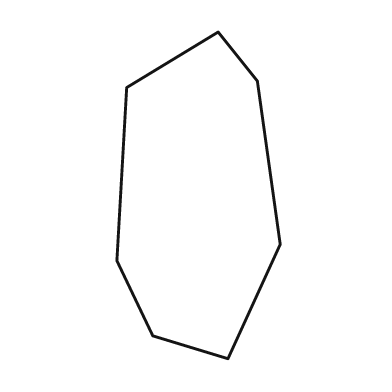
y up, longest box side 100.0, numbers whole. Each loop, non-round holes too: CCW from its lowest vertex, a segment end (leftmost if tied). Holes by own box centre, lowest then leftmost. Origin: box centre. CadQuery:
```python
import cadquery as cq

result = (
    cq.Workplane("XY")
    .moveTo(9.0, -50.0)
    .lineTo(25.0, -15.0)
    .lineTo(18.0, 35.0)
    .lineTo(6.0, 50.0)
    .lineTo(-22.0, 33.0)
    .lineTo(-25.0, -20.0)
    .lineTo(-14.0, -43.0)
    .close()
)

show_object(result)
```